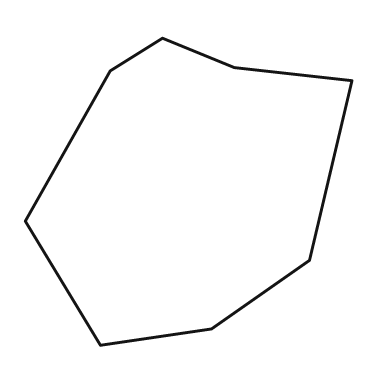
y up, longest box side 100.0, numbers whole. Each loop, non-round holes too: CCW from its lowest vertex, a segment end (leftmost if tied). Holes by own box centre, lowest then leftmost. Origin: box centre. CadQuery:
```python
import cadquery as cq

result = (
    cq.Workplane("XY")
    .moveTo(-27.0, -47.0)
    .lineTo(7.0, -42.0)
    .lineTo(37.0, -21.0)
    .lineTo(50.0, 34.0)
    .lineTo(14.0, 38.0)
    .lineTo(-8.0, 47.0)
    .lineTo(-24.0, 37.0)
    .lineTo(-50.0, -9.0)
    .close()
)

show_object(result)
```